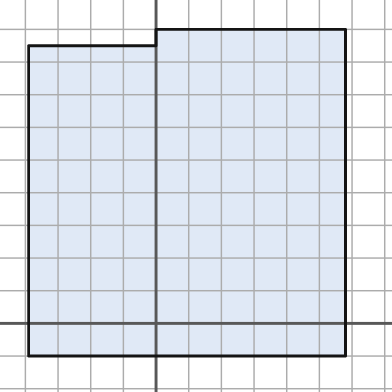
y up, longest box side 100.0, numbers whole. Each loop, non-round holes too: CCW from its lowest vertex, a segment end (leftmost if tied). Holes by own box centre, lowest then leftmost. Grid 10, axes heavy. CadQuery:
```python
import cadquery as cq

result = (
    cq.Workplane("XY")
    .moveTo(-39.0, -10.0)
    .lineTo(58.0, -10.0)
    .lineTo(58.0, 90.0)
    .lineTo(0.0, 90.0)
    .lineTo(0.0, 85.0)
    .lineTo(-39.0, 85.0)
    .close()
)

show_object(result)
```